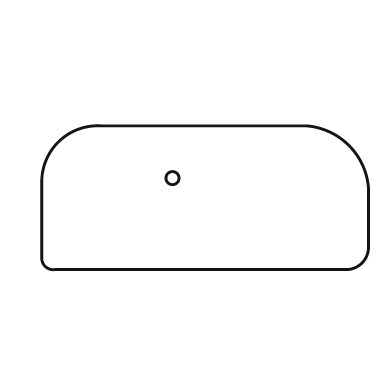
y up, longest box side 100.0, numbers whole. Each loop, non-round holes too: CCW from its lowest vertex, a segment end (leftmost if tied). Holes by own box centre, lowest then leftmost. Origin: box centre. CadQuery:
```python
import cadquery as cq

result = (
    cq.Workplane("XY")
    .moveTo(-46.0, -22.0)
    .lineTo(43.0, -22.0)
    .threePointArc((48.0, -20.0), (50.0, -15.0))
    .lineTo(50.0, 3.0)
    .threePointArc((44.0, 16.0), (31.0, 22.0))
    .lineTo(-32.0, 22.0)
    .threePointArc((-45.0, 17.0), (-50.0, 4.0))
    .lineTo(-50.0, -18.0)
    .threePointArc((-49.0, -21.0), (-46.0, -22.0))
    .close()
    .moveTo(-10.0, 6.0)
    .circle(2.0)
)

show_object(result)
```